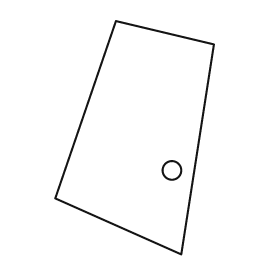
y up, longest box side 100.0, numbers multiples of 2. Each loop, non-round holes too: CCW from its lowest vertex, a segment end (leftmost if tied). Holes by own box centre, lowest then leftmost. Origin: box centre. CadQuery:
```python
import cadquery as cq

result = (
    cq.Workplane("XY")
    .moveTo(20.0, -50.0)
    .lineTo(34.0, 40.0)
    .lineTo(-8.0, 50.0)
    .lineTo(-34.0, -26.0)
    .close()
    .moveTo(16.0, -14.0)
    .circle(4.0)
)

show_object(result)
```